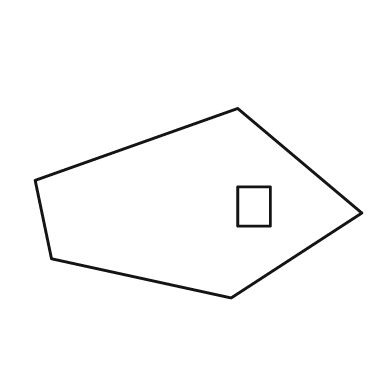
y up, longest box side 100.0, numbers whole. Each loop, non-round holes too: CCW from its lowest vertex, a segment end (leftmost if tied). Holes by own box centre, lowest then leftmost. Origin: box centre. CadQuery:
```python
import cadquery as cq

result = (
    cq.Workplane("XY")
    .moveTo(10.0, -29.0)
    .lineTo(50.0, -3.0)
    .lineTo(12.0, 29.0)
    .lineTo(-50.0, 7.0)
    .lineTo(-45.0, -17.0)
    .close()
    .moveTo(12.0, -7.0)
    .lineTo(22.0, -7.0)
    .lineTo(22.0, 5.0)
    .lineTo(12.0, 5.0)
    .close()
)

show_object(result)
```